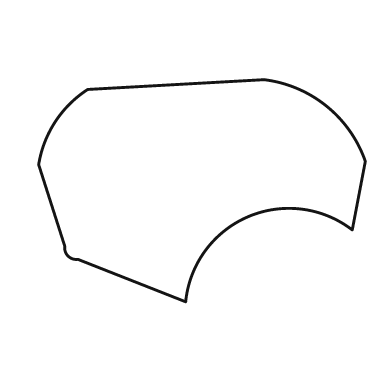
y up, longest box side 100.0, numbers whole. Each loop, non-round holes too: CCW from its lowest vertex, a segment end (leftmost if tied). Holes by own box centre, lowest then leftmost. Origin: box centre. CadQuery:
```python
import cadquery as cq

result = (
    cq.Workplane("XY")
    .moveTo(-5.0, -34.0)
    .threePointArc((14.0, -8.0), (46.0, -12.0))
    .lineTo(50.0, 9.0)
    .threePointArc((38.0, 26.0), (19.0, 34.0))
    .lineTo(-35.0, 31.0)
    .threePointArc((-45.0, 21.0), (-50.0, 8.0))
    .lineTo(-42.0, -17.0)
    .threePointArc((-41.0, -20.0), (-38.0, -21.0))
    .close()
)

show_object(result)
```